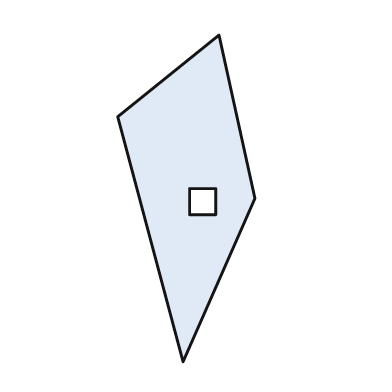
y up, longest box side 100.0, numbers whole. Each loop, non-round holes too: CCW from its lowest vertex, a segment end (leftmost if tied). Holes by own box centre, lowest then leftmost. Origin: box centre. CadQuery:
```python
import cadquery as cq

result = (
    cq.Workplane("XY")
    .moveTo(-1.0, -50.0)
    .lineTo(21.0, 0.0)
    .lineTo(10.0, 50.0)
    .lineTo(-21.0, 25.0)
    .close()
    .moveTo(1.0, -5.0)
    .lineTo(9.0, -5.0)
    .lineTo(9.0, 3.0)
    .lineTo(1.0, 3.0)
    .close()
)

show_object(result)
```